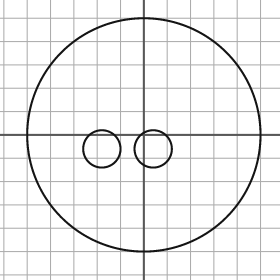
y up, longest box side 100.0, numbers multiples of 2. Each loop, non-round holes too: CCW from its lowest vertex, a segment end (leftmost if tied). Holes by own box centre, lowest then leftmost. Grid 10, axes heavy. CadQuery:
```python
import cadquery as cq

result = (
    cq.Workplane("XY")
    .moveTo(0.0, 0.0)
    .circle(50.0)
    .moveTo(-18.0, -6.0)
    .circle(8.0)
    .moveTo(4.0, -6.0)
    .circle(8.0)
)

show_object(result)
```